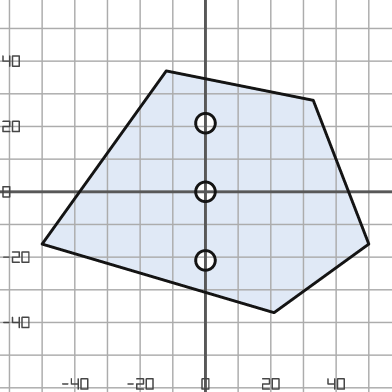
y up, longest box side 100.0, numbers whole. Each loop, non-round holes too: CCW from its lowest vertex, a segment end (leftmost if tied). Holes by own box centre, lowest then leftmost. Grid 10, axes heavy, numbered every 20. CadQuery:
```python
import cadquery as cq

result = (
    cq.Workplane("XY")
    .moveTo(21.0, -37.0)
    .lineTo(50.0, -16.0)
    .lineTo(33.0, 28.0)
    .lineTo(-12.0, 37.0)
    .lineTo(-50.0, -16.0)
    .close()
    .moveTo(0.0, -21.0)
    .circle(3.0)
    .moveTo(0.0, 0.0)
    .circle(3.0)
    .moveTo(0.0, 21.0)
    .circle(3.0)
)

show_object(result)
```